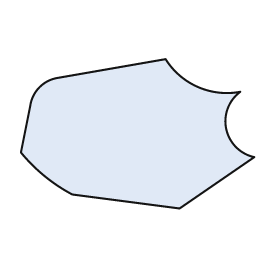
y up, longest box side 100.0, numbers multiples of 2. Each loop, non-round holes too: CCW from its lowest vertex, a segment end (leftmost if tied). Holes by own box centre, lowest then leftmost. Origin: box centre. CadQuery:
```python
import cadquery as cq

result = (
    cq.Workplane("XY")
    .moveTo(18.0, -32.0)
    .lineTo(50.0, -10.0)
    .threePointArc((38.0, 2.0), (44.0, 18.0))
    .threePointArc((26.0, 20.0), (12.0, 32.0))
    .lineTo(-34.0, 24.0)
    .threePointArc((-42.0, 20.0), (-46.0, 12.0))
    .lineTo(-50.0, -8.0)
    .threePointArc((-40.0, -18.0), (-28.0, -26.0))
    .close()
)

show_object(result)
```